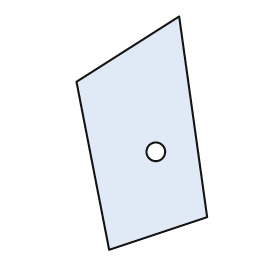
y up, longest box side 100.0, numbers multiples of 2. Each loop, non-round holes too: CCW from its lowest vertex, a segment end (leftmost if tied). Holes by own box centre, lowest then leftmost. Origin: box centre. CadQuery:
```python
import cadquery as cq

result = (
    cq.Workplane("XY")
    .moveTo(-14.0, -50.0)
    .lineTo(28.0, -36.0)
    .lineTo(16.0, 50.0)
    .lineTo(-28.0, 22.0)
    .close()
    .moveTo(6.0, -8.0)
    .circle(4.0)
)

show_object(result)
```